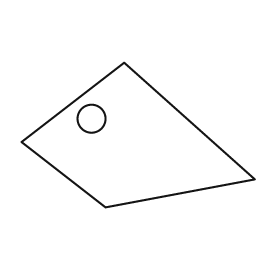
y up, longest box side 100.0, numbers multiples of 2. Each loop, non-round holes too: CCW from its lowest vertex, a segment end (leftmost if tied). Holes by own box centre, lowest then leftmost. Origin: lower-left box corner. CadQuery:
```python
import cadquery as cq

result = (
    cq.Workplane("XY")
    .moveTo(36.0, 0.0)
    .lineTo(100.0, 12.0)
    .lineTo(44.0, 62.0)
    .lineTo(0.0, 28.0)
    .close()
    .moveTo(30.0, 38.0)
    .circle(6.0)
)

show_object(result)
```